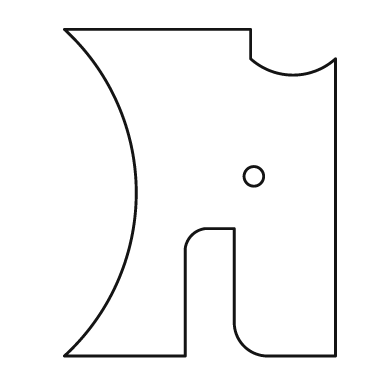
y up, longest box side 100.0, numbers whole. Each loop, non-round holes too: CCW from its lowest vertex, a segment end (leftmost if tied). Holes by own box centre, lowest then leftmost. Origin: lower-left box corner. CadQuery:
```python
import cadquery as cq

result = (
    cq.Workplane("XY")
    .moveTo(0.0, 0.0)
    .lineTo(37.0, 0.0)
    .lineTo(37.0, 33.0)
    .threePointArc((39.0, 37.0), (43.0, 39.0))
    .lineTo(52.0, 39.0)
    .lineTo(52.0, 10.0)
    .threePointArc((55.0, 3.0), (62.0, 0.0))
    .lineTo(83.0, 0.0)
    .lineTo(83.0, 91.0)
    .threePointArc((70.0, 86.0), (57.0, 91.0))
    .lineTo(57.0, 100.0)
    .lineTo(0.0, 100.0)
    .threePointArc((22.0, 50.0), (0.0, 0.0))
    .close()
    .moveTo(58.0, 55.0)
    .circle(3.0)
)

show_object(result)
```